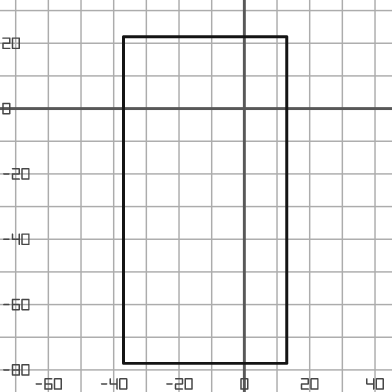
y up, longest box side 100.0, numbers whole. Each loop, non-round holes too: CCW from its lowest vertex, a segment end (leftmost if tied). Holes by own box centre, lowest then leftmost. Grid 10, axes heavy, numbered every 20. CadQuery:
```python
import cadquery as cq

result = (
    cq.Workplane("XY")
    .moveTo(-37.0, -78.0)
    .lineTo(13.0, -78.0)
    .lineTo(13.0, 22.0)
    .lineTo(-37.0, 22.0)
    .close()
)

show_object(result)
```